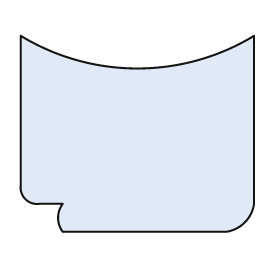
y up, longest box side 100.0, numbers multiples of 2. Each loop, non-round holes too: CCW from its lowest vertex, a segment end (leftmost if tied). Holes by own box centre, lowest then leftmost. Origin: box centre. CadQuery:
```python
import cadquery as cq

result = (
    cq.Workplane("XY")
    .moveTo(-32.0, -42.0)
    .lineTo(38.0, -42.0)
    .threePointArc((46.0, -38.0), (50.0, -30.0))
    .lineTo(50.0, 42.0)
    .threePointArc((0.0, 28.0), (-50.0, 42.0))
    .lineTo(-50.0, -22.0)
    .threePointArc((-48.0, -28.0), (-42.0, -30.0))
    .lineTo(-32.0, -30.0)
    .threePointArc((-34.0, -36.0), (-32.0, -42.0))
    .close()
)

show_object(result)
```